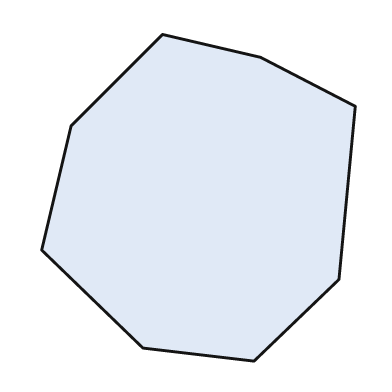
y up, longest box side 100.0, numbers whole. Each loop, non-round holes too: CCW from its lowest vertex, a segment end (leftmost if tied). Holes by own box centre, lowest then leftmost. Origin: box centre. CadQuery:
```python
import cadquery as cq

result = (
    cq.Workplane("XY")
    .moveTo(17.0, -50.0)
    .lineTo(43.0, -25.0)
    .lineTo(48.0, 28.0)
    .lineTo(19.0, 43.0)
    .lineTo(-11.0, 50.0)
    .lineTo(-39.0, 22.0)
    .lineTo(-48.0, -16.0)
    .lineTo(-17.0, -46.0)
    .close()
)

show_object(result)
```